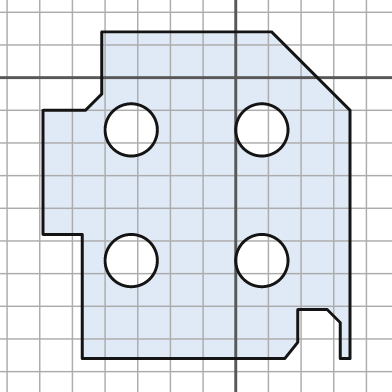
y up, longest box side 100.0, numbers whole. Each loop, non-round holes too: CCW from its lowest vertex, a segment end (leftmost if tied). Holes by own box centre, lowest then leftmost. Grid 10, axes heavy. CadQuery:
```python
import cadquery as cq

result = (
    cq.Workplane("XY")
    .moveTo(-47.0, -86.0)
    .lineTo(15.0, -86.0)
    .lineTo(19.0, -81.0)
    .lineTo(19.0, -71.0)
    .lineTo(28.0, -71.0)
    .lineTo(32.0, -75.0)
    .lineTo(32.0, -86.0)
    .lineTo(35.0, -86.0)
    .lineTo(35.0, -10.0)
    .lineTo(11.0, 14.0)
    .lineTo(-41.0, 14.0)
    .lineTo(-41.0, -5.0)
    .lineTo(-46.0, -10.0)
    .lineTo(-59.0, -10.0)
    .lineTo(-59.0, -48.0)
    .lineTo(-47.0, -48.0)
    .close()
    .moveTo(-32.0, -56.0)
    .circle(8.0)
    .moveTo(8.0, -56.0)
    .circle(8.0)
    .moveTo(-32.0, -16.0)
    .circle(8.0)
    .moveTo(8.0, -16.0)
    .circle(8.0)
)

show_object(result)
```